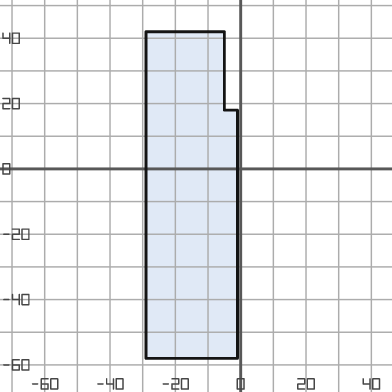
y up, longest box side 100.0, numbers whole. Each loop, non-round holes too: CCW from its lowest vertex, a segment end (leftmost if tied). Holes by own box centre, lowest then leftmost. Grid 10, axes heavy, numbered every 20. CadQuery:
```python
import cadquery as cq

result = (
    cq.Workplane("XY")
    .moveTo(-29.0, -58.0)
    .lineTo(-1.0, -58.0)
    .lineTo(-1.0, 18.0)
    .lineTo(-5.0, 18.0)
    .lineTo(-5.0, 42.0)
    .lineTo(-29.0, 42.0)
    .close()
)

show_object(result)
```